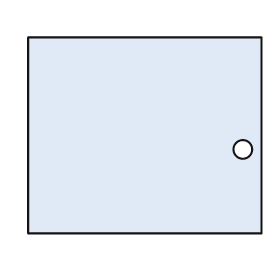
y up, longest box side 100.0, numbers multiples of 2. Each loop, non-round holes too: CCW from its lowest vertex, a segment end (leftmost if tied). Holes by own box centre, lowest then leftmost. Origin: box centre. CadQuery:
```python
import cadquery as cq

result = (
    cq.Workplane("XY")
    .moveTo(-50.0, -42.0)
    .lineTo(50.0, -42.0)
    .lineTo(50.0, 42.0)
    .lineTo(-50.0, 42.0)
    .close()
    .moveTo(42.0, -6.0)
    .circle(4.0)
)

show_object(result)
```